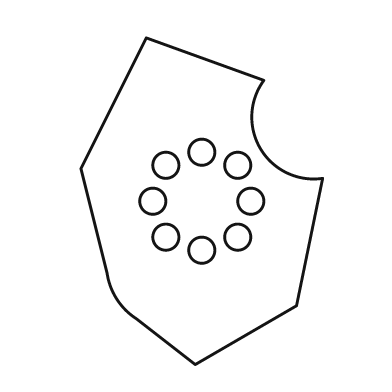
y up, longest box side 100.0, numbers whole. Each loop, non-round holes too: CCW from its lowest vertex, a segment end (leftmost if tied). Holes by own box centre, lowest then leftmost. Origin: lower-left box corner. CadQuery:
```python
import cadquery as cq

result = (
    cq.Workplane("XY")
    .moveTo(35.0, 0.0)
    .lineTo(66.0, 18.0)
    .lineTo(74.0, 57.0)
    .threePointArc((55.0, 66.0), (56.0, 87.0))
    .lineTo(20.0, 100.0)
    .lineTo(0.0, 60.0)
    .lineTo(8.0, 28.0)
    .threePointArc((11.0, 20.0), (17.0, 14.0))
    .close()
    .moveTo(37.0, 35.0)
    .circle(4.0)
    .moveTo(26.0, 39.0)
    .circle(4.0)
    .moveTo(48.0, 39.0)
    .circle(4.0)
    .moveTo(22.0, 50.0)
    .circle(4.0)
    .moveTo(52.0, 50.0)
    .circle(4.0)
    .moveTo(26.0, 61.0)
    .circle(4.0)
    .moveTo(48.0, 61.0)
    .circle(4.0)
    .moveTo(37.0, 65.0)
    .circle(4.0)
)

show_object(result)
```